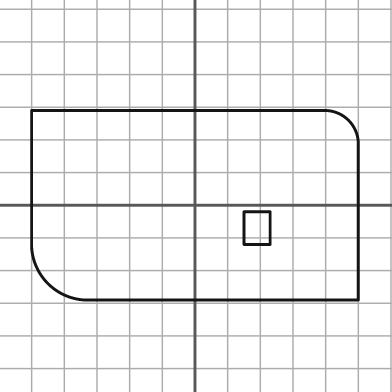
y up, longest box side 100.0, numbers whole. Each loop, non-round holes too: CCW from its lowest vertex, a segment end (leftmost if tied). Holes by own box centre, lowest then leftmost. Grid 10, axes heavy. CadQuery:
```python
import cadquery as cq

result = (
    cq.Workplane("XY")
    .moveTo(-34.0, -29.0)
    .lineTo(50.0, -29.0)
    .lineTo(50.0, 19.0)
    .threePointArc((47.0, 26.0), (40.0, 29.0))
    .lineTo(-50.0, 29.0)
    .lineTo(-50.0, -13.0)
    .threePointArc((-45.0, -24.0), (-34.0, -29.0))
    .close()
    .moveTo(15.0, -12.0)
    .lineTo(23.0, -12.0)
    .lineTo(23.0, -2.0)
    .lineTo(15.0, -2.0)
    .close()
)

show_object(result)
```